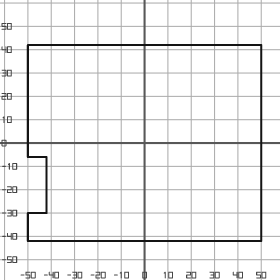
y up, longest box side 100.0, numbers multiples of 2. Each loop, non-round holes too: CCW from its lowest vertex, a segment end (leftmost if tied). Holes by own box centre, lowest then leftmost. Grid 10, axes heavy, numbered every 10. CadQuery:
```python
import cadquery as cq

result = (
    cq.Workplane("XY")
    .moveTo(-50.0, -42.0)
    .lineTo(50.0, -42.0)
    .lineTo(50.0, 42.0)
    .lineTo(-50.0, 42.0)
    .lineTo(-50.0, -6.0)
    .lineTo(-42.0, -6.0)
    .lineTo(-42.0, -30.0)
    .lineTo(-50.0, -30.0)
    .close()
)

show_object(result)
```